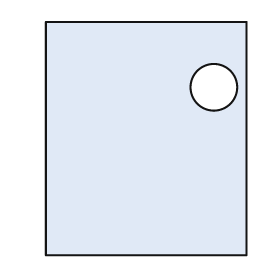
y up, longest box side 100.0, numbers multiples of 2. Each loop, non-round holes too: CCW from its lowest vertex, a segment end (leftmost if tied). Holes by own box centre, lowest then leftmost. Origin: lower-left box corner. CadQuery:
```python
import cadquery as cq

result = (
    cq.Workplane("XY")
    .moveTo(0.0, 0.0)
    .lineTo(86.0, 0.0)
    .lineTo(86.0, 100.0)
    .lineTo(0.0, 100.0)
    .close()
    .moveTo(72.0, 72.0)
    .circle(10.0)
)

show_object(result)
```